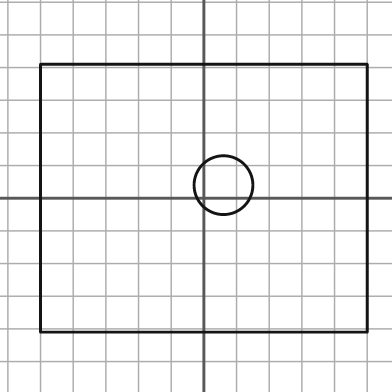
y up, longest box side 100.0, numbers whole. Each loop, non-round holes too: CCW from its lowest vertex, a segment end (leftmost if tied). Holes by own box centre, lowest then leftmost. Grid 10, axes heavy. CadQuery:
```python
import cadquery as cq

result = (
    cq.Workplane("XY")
    .moveTo(-50.0, -41.0)
    .lineTo(50.0, -41.0)
    .lineTo(50.0, 41.0)
    .lineTo(-50.0, 41.0)
    .close()
    .moveTo(6.0, 4.0)
    .circle(9.0)
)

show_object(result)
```